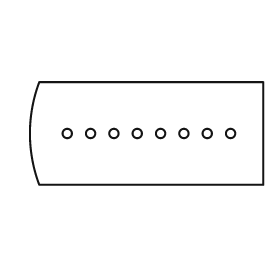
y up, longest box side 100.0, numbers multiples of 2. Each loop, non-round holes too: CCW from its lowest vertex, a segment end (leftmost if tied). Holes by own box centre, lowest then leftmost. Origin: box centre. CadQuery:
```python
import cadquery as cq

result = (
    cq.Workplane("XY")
    .moveTo(-46.0, -22.0)
    .lineTo(50.0, -22.0)
    .lineTo(50.0, 22.0)
    .lineTo(-46.0, 22.0)
    .threePointArc((-50.0, 0.0), (-46.0, -22.0))
    .close()
    .moveTo(-34.0, 0.0)
    .circle(2.0)
    .moveTo(-24.0, 0.0)
    .circle(2.0)
    .moveTo(-14.0, 0.0)
    .circle(2.0)
    .moveTo(-4.0, 0.0)
    .circle(2.0)
    .moveTo(6.0, 0.0)
    .circle(2.0)
    .moveTo(16.0, 0.0)
    .circle(2.0)
    .moveTo(26.0, 0.0)
    .circle(2.0)
    .moveTo(36.0, 0.0)
    .circle(2.0)
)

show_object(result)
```